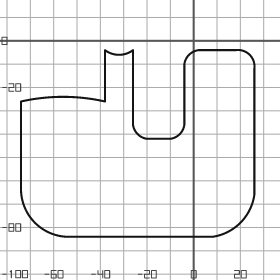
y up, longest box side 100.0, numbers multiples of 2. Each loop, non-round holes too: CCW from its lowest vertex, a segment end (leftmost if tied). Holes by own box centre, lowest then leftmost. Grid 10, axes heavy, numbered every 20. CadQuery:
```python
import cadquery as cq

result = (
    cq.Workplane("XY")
    .moveTo(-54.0, -84.0)
    .lineTo(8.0, -84.0)
    .threePointArc((20.0, -78.0), (26.0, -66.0))
    .lineTo(26.0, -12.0)
    .threePointArc((24.0, -6.0), (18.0, -4.0))
    .lineTo(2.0, -4.0)
    .threePointArc((-2.0, -6.0), (-4.0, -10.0))
    .lineTo(-4.0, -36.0)
    .threePointArc((-6.0, -40.0), (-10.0, -42.0))
    .lineTo(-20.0, -42.0)
    .threePointArc((-24.0, -40.0), (-26.0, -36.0))
    .lineTo(-26.0, -4.0)
    .threePointArc((-32.0, -6.0), (-38.0, -4.0))
    .lineTo(-38.0, -26.0)
    .threePointArc((-56.0, -24.0), (-74.0, -26.0))
    .lineTo(-74.0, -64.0)
    .threePointArc((-68.0, -78.0), (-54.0, -84.0))
    .close()
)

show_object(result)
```